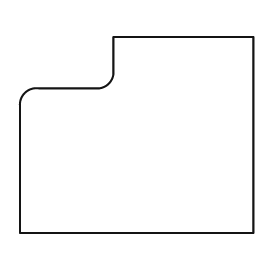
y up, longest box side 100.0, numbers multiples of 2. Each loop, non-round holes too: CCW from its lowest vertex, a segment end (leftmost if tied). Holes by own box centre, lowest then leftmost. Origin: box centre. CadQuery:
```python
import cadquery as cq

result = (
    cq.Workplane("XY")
    .moveTo(-50.0, -42.0)
    .lineTo(50.0, -42.0)
    .lineTo(50.0, 42.0)
    .lineTo(-10.0, 42.0)
    .lineTo(-10.0, 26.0)
    .threePointArc((-12.0, 22.0), (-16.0, 20.0))
    .lineTo(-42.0, 20.0)
    .threePointArc((-48.0, 18.0), (-50.0, 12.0))
    .close()
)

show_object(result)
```